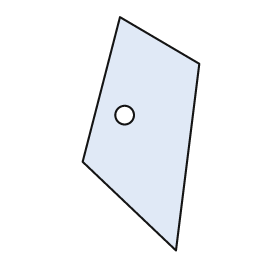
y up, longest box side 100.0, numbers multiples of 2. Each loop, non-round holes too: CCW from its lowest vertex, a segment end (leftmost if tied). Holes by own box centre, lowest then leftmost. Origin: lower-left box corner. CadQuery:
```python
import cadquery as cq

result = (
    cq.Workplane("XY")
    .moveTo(40.0, 0.0)
    .lineTo(50.0, 80.0)
    .lineTo(16.0, 100.0)
    .lineTo(0.0, 38.0)
    .close()
    .moveTo(18.0, 58.0)
    .circle(4.0)
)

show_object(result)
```